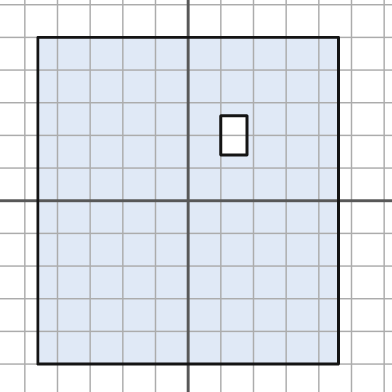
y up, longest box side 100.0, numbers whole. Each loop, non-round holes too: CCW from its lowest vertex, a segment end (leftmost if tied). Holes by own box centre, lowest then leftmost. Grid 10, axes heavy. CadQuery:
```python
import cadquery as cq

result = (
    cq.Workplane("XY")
    .moveTo(-46.0, -50.0)
    .lineTo(46.0, -50.0)
    .lineTo(46.0, 50.0)
    .lineTo(-46.0, 50.0)
    .close()
    .moveTo(10.0, 14.0)
    .lineTo(18.0, 14.0)
    .lineTo(18.0, 26.0)
    .lineTo(10.0, 26.0)
    .close()
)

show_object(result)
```